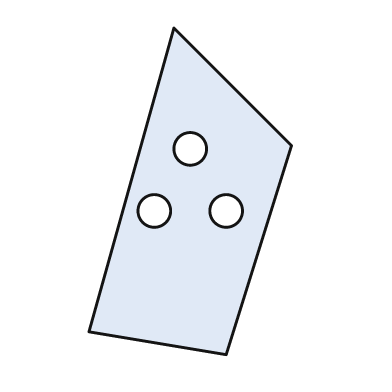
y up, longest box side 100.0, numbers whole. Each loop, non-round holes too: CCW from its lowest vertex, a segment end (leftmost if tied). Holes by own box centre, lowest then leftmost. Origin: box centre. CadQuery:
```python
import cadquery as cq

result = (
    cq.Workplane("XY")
    .moveTo(11.0, -50.0)
    .lineTo(31.0, 14.0)
    .lineTo(-5.0, 50.0)
    .lineTo(-31.0, -43.0)
    .close()
    .moveTo(-11.0, -6.0)
    .circle(5.0)
    .moveTo(11.0, -6.0)
    .circle(5.0)
    .moveTo(0.0, 13.0)
    .circle(5.0)
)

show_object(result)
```